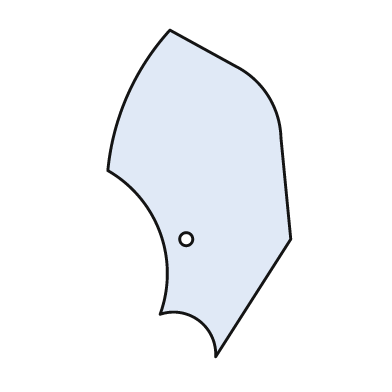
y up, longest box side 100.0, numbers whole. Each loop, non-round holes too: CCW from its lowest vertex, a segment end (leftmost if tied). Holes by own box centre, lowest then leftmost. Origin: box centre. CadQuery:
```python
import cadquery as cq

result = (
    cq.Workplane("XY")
    .moveTo(5.0, -50.0)
    .lineTo(28.0, -14.0)
    .lineTo(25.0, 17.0)
    .threePointArc((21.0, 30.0), (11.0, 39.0))
    .lineTo(-9.0, 50.0)
    .threePointArc((-22.0, 30.0), (-28.0, 7.0))
    .threePointArc((-12.0, -12.0), (-12.0, -37.0))
    .threePointArc((0.0, -39.0), (5.0, -50.0))
    .close()
    .moveTo(-4.0, -14.0)
    .circle(2.0)
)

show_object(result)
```